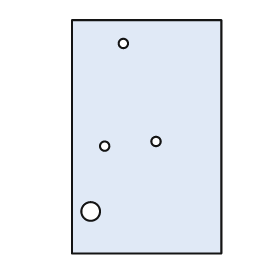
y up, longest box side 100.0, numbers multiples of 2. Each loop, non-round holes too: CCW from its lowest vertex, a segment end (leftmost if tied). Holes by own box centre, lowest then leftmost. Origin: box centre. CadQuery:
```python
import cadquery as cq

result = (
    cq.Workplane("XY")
    .moveTo(-32.0, -50.0)
    .lineTo(32.0, -50.0)
    .lineTo(32.0, 50.0)
    .lineTo(-32.0, 50.0)
    .close()
    .moveTo(-24.0, -32.0)
    .circle(4.0)
    .moveTo(-18.0, -4.0)
    .circle(2.0)
    .moveTo(4.0, -2.0)
    .circle(2.0)
    .moveTo(-10.0, 40.0)
    .circle(2.0)
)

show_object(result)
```